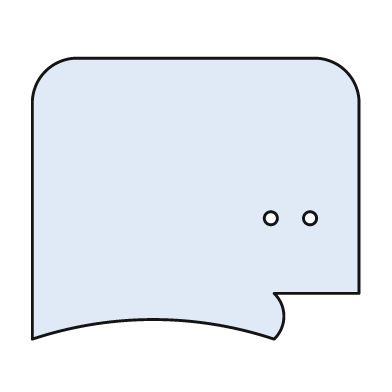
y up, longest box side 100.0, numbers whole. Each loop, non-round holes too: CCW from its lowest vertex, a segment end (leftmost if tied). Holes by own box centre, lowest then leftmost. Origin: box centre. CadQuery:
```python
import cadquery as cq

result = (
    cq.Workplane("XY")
    .moveTo(-50.0, -43.0)
    .threePointArc((-13.0, -37.0), (24.0, -43.0))
    .threePointArc((27.0, -36.0), (24.0, -29.0))
    .lineTo(50.0, -29.0)
    .lineTo(50.0, 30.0)
    .threePointArc((46.0, 39.0), (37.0, 43.0))
    .lineTo(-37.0, 43.0)
    .threePointArc((-46.0, 39.0), (-50.0, 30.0))
    .close()
    .moveTo(23.0, -6.0)
    .circle(2.0)
    .moveTo(35.0, -6.0)
    .circle(2.0)
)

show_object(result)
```